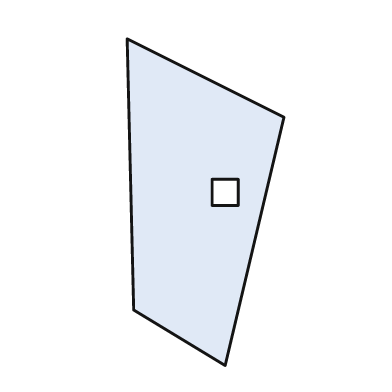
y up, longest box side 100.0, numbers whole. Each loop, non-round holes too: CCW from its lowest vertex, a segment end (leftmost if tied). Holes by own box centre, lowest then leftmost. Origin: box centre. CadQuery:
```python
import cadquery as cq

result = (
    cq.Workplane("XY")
    .moveTo(6.0, -50.0)
    .lineTo(24.0, 26.0)
    .lineTo(-24.0, 50.0)
    .lineTo(-22.0, -33.0)
    .close()
    .moveTo(2.0, -1.0)
    .lineTo(10.0, -1.0)
    .lineTo(10.0, 7.0)
    .lineTo(2.0, 7.0)
    .close()
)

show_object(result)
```